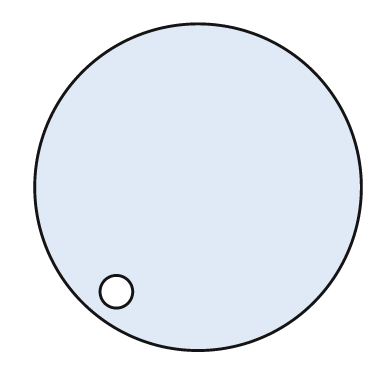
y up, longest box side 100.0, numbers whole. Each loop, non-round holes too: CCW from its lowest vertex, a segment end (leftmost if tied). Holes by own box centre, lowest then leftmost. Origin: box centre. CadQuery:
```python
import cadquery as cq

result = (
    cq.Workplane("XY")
    .moveTo(0.0, 0.0)
    .circle(50.0)
    .moveTo(-25.0, -32.0)
    .circle(5.0)
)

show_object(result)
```